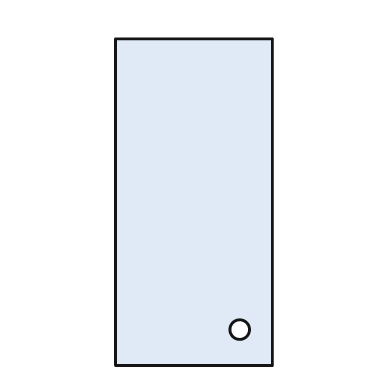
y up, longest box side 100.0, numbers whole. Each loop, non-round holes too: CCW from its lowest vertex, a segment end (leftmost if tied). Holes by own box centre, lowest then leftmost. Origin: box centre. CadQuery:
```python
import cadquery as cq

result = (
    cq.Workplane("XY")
    .moveTo(-24.0, -50.0)
    .lineTo(24.0, -50.0)
    .lineTo(24.0, 50.0)
    .lineTo(-24.0, 50.0)
    .close()
    .moveTo(14.0, -39.0)
    .circle(3.0)
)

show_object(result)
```